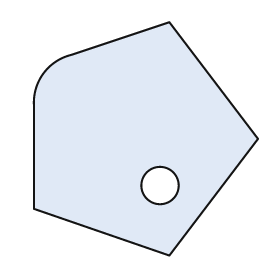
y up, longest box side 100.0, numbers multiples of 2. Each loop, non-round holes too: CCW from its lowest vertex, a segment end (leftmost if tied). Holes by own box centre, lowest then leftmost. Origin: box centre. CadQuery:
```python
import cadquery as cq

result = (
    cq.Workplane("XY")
    .moveTo(10.0, -50.0)
    .lineTo(48.0, 0.0)
    .lineTo(10.0, 50.0)
    .lineTo(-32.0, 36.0)
    .threePointArc((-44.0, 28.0), (-48.0, 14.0))
    .lineTo(-48.0, -30.0)
    .close()
    .moveTo(6.0, -20.0)
    .circle(8.0)
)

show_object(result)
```